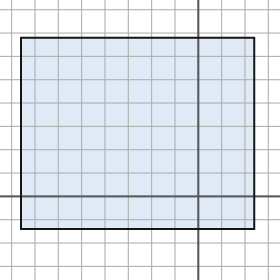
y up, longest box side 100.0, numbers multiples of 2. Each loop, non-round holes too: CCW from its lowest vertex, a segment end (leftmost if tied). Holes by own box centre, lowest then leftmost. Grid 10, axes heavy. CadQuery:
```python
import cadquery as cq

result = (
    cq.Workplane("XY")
    .moveTo(-76.0, -14.0)
    .lineTo(24.0, -14.0)
    .lineTo(24.0, 68.0)
    .lineTo(-76.0, 68.0)
    .close()
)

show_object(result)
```